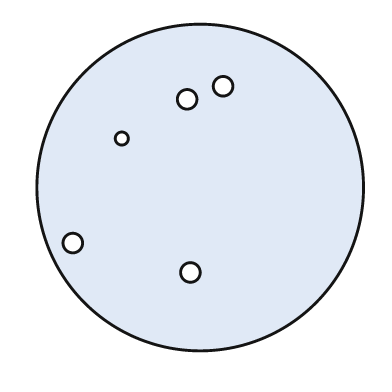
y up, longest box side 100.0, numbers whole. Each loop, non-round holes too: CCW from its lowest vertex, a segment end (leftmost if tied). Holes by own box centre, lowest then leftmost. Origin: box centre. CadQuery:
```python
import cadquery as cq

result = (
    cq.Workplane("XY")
    .moveTo(0.0, 0.0)
    .circle(50.0)
    .moveTo(-3.0, -26.0)
    .circle(3.0)
    .moveTo(-39.0, -17.0)
    .circle(3.0)
    .moveTo(-24.0, 15.0)
    .circle(2.0)
    .moveTo(-4.0, 27.0)
    .circle(3.0)
    .moveTo(7.0, 31.0)
    .circle(3.0)
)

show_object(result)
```